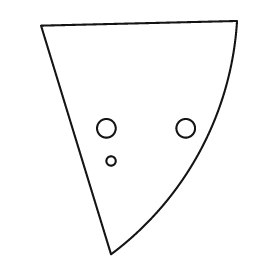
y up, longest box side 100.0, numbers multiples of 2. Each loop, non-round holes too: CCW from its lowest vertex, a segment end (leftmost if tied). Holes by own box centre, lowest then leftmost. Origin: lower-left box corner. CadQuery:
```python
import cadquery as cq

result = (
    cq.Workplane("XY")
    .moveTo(30.0, 0.0)
    .threePointArc((68.0, 44.0), (84.0, 100.0))
    .lineTo(0.0, 98.0)
    .close()
    .moveTo(30.0, 40.0)
    .circle(2.0)
    .moveTo(28.0, 54.0)
    .circle(4.0)
    .moveTo(62.0, 54.0)
    .circle(4.0)
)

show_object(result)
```